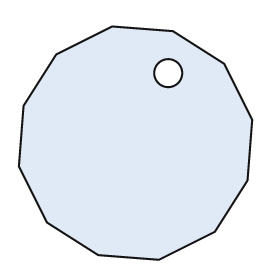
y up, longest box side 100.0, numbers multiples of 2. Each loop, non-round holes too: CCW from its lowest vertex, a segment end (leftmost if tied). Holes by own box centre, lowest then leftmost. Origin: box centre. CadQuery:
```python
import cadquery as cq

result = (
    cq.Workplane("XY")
    .moveTo(10.0, -50.0)
    .lineTo(34.0, -38.0)
    .lineTo(48.0, -16.0)
    .lineTo(50.0, 10.0)
    .lineTo(38.0, 34.0)
    .lineTo(16.0, 48.0)
    .lineTo(-10.0, 50.0)
    .lineTo(-34.0, 38.0)
    .lineTo(-48.0, 16.0)
    .lineTo(-50.0, -10.0)
    .lineTo(-38.0, -34.0)
    .lineTo(-16.0, -48.0)
    .close()
    .moveTo(14.0, 30.0)
    .circle(6.0)
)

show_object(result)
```